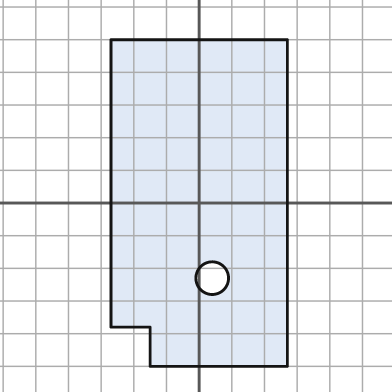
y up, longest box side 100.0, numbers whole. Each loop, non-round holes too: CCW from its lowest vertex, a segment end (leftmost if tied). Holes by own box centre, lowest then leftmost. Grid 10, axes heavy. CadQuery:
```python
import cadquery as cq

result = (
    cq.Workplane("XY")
    .moveTo(-15.0, -50.0)
    .lineTo(27.0, -50.0)
    .lineTo(27.0, 50.0)
    .lineTo(-27.0, 50.0)
    .lineTo(-27.0, -38.0)
    .lineTo(-15.0, -38.0)
    .close()
    .moveTo(4.0, -23.0)
    .circle(5.0)
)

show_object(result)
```